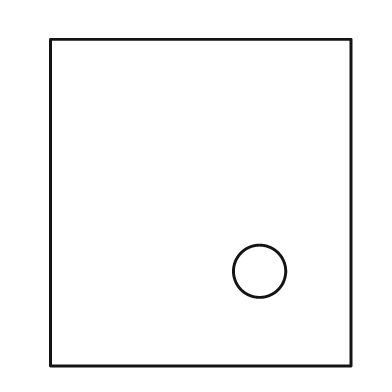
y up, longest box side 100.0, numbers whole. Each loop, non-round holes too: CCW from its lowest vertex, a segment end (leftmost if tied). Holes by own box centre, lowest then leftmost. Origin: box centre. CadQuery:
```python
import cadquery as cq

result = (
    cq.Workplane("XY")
    .moveTo(-46.0, -50.0)
    .lineTo(46.0, -50.0)
    .lineTo(46.0, 50.0)
    .lineTo(-46.0, 50.0)
    .close()
    .moveTo(18.0, -21.0)
    .circle(8.0)
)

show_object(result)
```